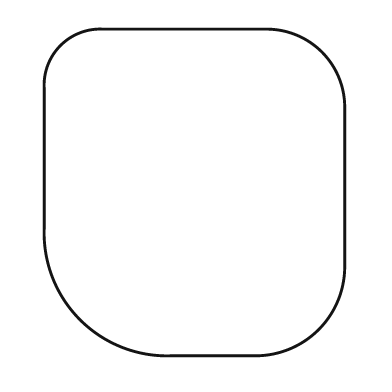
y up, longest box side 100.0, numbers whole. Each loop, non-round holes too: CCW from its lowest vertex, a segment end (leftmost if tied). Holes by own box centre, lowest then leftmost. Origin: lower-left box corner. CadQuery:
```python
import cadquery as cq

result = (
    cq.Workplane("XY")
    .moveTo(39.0, 0.0)
    .lineTo(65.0, 0.0)
    .threePointArc((84.0, 8.0), (92.0, 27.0))
    .lineTo(92.0, 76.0)
    .threePointArc((85.0, 93.0), (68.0, 100.0))
    .lineTo(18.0, 100.0)
    .threePointArc((5.0, 95.0), (0.0, 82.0))
    .lineTo(0.0, 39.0)
    .threePointArc((11.0, 11.0), (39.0, 0.0))
    .close()
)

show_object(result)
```